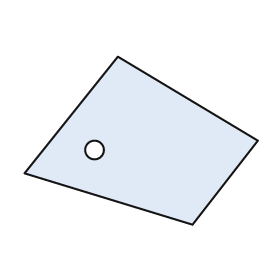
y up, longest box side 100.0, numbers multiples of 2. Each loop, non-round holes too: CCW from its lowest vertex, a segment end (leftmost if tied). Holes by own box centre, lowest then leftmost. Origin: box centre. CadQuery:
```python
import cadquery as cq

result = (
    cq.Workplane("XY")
    .moveTo(22.0, -36.0)
    .lineTo(50.0, 0.0)
    .lineTo(-10.0, 36.0)
    .lineTo(-50.0, -14.0)
    .close()
    .moveTo(-20.0, -4.0)
    .circle(4.0)
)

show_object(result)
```